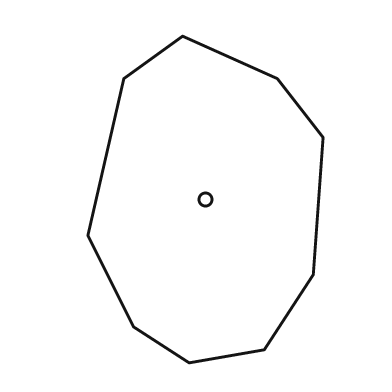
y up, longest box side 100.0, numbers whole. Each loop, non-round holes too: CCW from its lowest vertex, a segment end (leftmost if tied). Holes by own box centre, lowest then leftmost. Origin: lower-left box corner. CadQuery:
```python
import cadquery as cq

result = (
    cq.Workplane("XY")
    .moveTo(31.0, 0.0)
    .lineTo(54.0, 4.0)
    .lineTo(69.0, 27.0)
    .lineTo(72.0, 69.0)
    .lineTo(58.0, 87.0)
    .lineTo(29.0, 100.0)
    .lineTo(11.0, 87.0)
    .lineTo(0.0, 39.0)
    .lineTo(14.0, 11.0)
    .close()
    .moveTo(36.0, 50.0)
    .circle(2.0)
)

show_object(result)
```